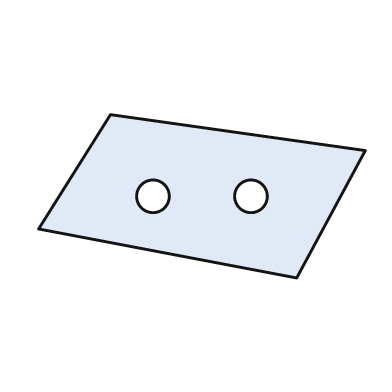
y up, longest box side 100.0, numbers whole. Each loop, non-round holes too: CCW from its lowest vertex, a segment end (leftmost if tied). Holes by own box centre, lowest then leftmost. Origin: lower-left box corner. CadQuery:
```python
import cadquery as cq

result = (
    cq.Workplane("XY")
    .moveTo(79.0, 0.0)
    .lineTo(100.0, 39.0)
    .lineTo(22.0, 50.0)
    .lineTo(0.0, 15.0)
    .close()
    .moveTo(35.0, 25.0)
    .circle(5.0)
    .moveTo(65.0, 25.0)
    .circle(5.0)
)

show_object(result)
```